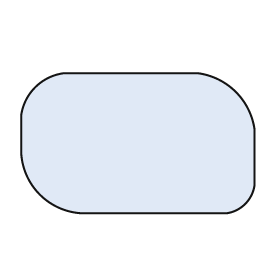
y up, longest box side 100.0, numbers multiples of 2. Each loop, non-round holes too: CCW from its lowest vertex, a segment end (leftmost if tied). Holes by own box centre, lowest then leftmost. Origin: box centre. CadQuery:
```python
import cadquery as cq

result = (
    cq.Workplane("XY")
    .moveTo(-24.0, -30.0)
    .lineTo(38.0, -30.0)
    .threePointArc((46.0, -26.0), (50.0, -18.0))
    .lineTo(50.0, 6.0)
    .threePointArc((42.0, 22.0), (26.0, 30.0))
    .lineTo(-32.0, 30.0)
    .threePointArc((-44.0, 24.0), (-50.0, 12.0))
    .lineTo(-50.0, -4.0)
    .threePointArc((-42.0, -22.0), (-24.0, -30.0))
    .close()
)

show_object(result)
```